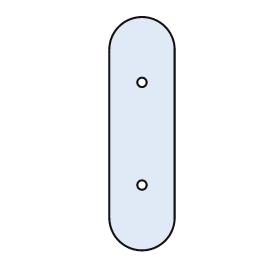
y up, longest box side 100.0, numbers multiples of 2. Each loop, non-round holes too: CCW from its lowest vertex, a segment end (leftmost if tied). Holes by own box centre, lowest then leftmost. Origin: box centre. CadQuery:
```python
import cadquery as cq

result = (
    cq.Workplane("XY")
    .moveTo(-14.0, -36.0)
    .threePointArc((0.0, -50.0), (14.0, -36.0))
    .lineTo(14.0, 36.0)
    .threePointArc((0.0, 50.0), (-14.0, 36.0))
    .close()
    .moveTo(0.0, -22.0)
    .circle(2.0)
    .moveTo(0.0, 22.0)
    .circle(2.0)
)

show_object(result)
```